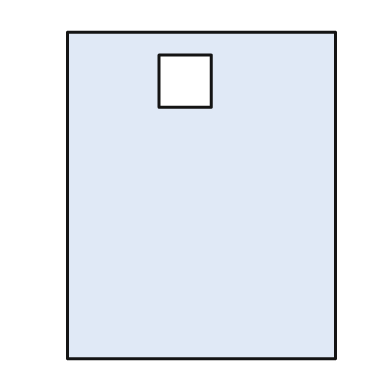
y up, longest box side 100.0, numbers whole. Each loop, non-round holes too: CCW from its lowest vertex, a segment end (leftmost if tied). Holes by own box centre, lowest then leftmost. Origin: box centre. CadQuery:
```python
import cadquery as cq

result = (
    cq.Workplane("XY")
    .moveTo(-41.0, -50.0)
    .lineTo(41.0, -50.0)
    .lineTo(41.0, 50.0)
    .lineTo(-41.0, 50.0)
    .close()
    .moveTo(-13.0, 27.0)
    .lineTo(3.0, 27.0)
    .lineTo(3.0, 43.0)
    .lineTo(-13.0, 43.0)
    .close()
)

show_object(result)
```